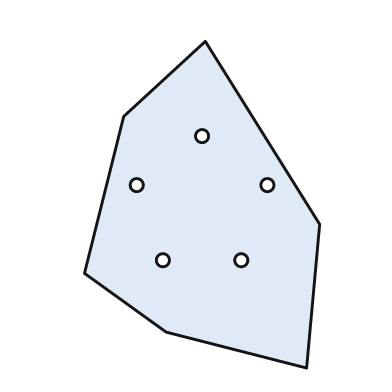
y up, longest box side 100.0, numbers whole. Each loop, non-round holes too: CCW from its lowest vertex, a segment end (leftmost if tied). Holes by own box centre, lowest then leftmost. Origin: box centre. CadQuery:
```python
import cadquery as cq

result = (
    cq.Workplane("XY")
    .moveTo(32.0, -50.0)
    .lineTo(36.0, -6.0)
    .lineTo(1.0, 50.0)
    .lineTo(-24.0, 27.0)
    .lineTo(-36.0, -21.0)
    .lineTo(-11.0, -39.0)
    .close()
    .moveTo(-12.0, -17.0)
    .circle(2.0)
    .moveTo(12.0, -17.0)
    .circle(2.0)
    .moveTo(-20.0, 6.0)
    .circle(2.0)
    .moveTo(20.0, 6.0)
    .circle(2.0)
    .moveTo(0.0, 21.0)
    .circle(2.0)
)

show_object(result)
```